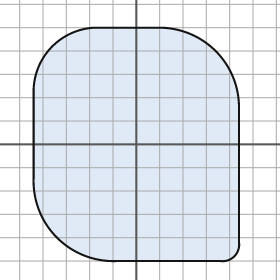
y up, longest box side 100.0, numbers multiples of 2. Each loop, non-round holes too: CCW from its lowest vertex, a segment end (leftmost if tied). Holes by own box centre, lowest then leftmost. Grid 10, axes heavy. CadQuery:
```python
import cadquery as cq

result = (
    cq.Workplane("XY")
    .moveTo(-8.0, -50.0)
    .lineTo(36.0, -50.0)
    .threePointArc((42.0, -48.0), (44.0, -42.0))
    .lineTo(44.0, 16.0)
    .threePointArc((34.0, 40.0), (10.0, 50.0))
    .lineTo(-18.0, 50.0)
    .threePointArc((-36.0, 42.0), (-44.0, 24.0))
    .lineTo(-44.0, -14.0)
    .threePointArc((-34.0, -40.0), (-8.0, -50.0))
    .close()
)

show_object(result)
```